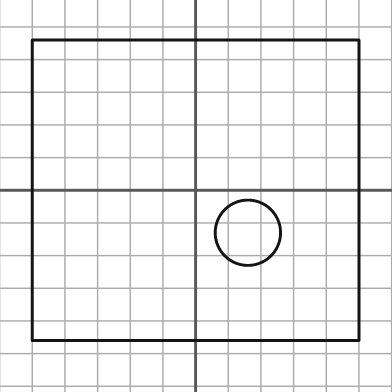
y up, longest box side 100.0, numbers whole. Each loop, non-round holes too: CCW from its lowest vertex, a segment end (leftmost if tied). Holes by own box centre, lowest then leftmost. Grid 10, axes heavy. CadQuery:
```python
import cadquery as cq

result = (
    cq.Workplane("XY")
    .moveTo(-50.0, -46.0)
    .lineTo(50.0, -46.0)
    .lineTo(50.0, 46.0)
    .lineTo(-50.0, 46.0)
    .close()
    .moveTo(16.0, -13.0)
    .circle(10.0)
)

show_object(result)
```